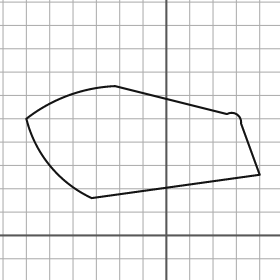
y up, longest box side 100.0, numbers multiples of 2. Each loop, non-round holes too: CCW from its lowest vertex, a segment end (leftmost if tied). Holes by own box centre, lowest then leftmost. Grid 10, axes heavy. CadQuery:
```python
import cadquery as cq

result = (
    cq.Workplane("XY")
    .moveTo(-32.0, 16.0)
    .lineTo(40.0, 26.0)
    .lineTo(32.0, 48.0)
    .threePointArc((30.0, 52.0), (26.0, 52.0))
    .lineTo(-22.0, 64.0)
    .threePointArc((-42.0, 60.0), (-60.0, 50.0))
    .threePointArc((-50.0, 30.0), (-32.0, 16.0))
    .close()
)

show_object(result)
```